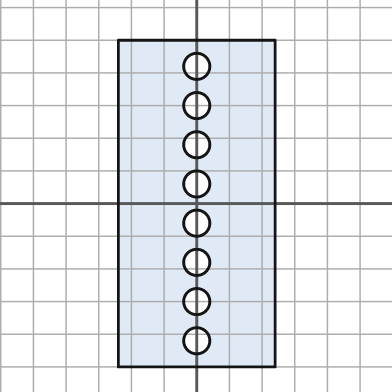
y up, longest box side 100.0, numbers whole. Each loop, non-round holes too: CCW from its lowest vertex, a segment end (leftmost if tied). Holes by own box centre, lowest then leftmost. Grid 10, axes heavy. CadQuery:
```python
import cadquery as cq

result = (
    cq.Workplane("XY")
    .moveTo(-24.0, -50.0)
    .lineTo(24.0, -50.0)
    .lineTo(24.0, 50.0)
    .lineTo(-24.0, 50.0)
    .close()
    .moveTo(0.0, -42.0)
    .circle(4.0)
    .moveTo(0.0, -30.0)
    .circle(4.0)
    .moveTo(0.0, -18.0)
    .circle(4.0)
    .moveTo(0.0, -6.0)
    .circle(4.0)
    .moveTo(0.0, 6.0)
    .circle(4.0)
    .moveTo(0.0, 18.0)
    .circle(4.0)
    .moveTo(0.0, 30.0)
    .circle(4.0)
    .moveTo(0.0, 42.0)
    .circle(4.0)
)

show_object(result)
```